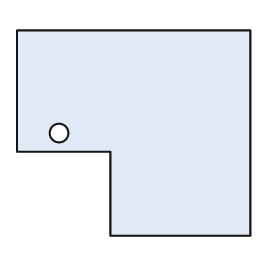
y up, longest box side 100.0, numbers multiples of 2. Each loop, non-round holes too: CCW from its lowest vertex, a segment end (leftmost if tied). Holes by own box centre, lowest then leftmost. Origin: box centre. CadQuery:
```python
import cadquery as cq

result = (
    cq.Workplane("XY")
    .moveTo(-10.0, -44.0)
    .lineTo(50.0, -44.0)
    .lineTo(50.0, 44.0)
    .lineTo(-50.0, 44.0)
    .lineTo(-50.0, -8.0)
    .lineTo(-10.0, -8.0)
    .close()
    .moveTo(-32.0, 0.0)
    .circle(4.0)
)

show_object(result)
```